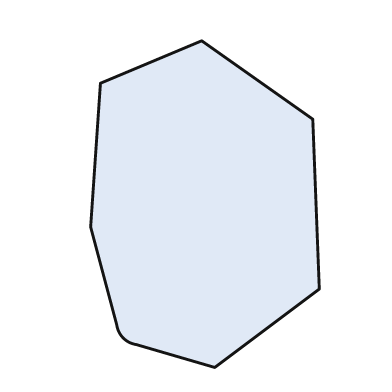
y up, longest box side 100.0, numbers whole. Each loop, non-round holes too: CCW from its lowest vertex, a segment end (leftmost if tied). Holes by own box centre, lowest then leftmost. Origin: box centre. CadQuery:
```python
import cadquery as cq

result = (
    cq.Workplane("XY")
    .moveTo(3.0, -50.0)
    .lineTo(35.0, -26.0)
    .lineTo(33.0, 26.0)
    .lineTo(-1.0, 50.0)
    .lineTo(-32.0, 37.0)
    .lineTo(-35.0, -7.0)
    .lineTo(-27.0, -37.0)
    .threePointArc((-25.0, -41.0), (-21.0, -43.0))
    .close()
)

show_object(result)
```